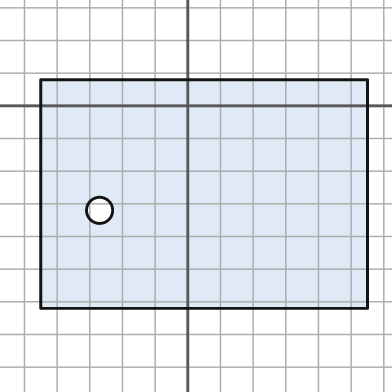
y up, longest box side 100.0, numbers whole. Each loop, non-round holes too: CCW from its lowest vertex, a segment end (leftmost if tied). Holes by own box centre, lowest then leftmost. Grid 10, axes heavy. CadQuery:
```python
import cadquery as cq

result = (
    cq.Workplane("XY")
    .moveTo(-45.0, -62.0)
    .lineTo(55.0, -62.0)
    .lineTo(55.0, 8.0)
    .lineTo(-45.0, 8.0)
    .close()
    .moveTo(-27.0, -32.0)
    .circle(4.0)
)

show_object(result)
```